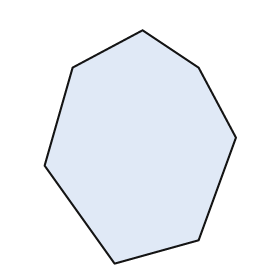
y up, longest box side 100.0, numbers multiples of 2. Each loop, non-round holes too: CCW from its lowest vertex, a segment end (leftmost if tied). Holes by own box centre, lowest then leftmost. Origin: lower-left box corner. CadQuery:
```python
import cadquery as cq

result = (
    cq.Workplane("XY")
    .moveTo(30.0, 0.0)
    .lineTo(66.0, 10.0)
    .lineTo(82.0, 54.0)
    .lineTo(66.0, 84.0)
    .lineTo(42.0, 100.0)
    .lineTo(12.0, 84.0)
    .lineTo(0.0, 42.0)
    .close()
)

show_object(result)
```